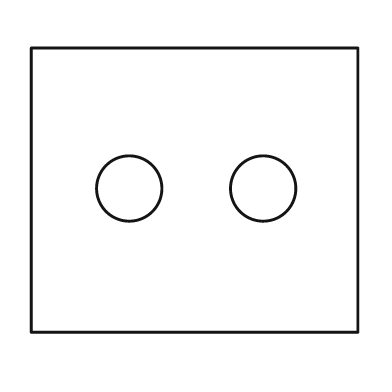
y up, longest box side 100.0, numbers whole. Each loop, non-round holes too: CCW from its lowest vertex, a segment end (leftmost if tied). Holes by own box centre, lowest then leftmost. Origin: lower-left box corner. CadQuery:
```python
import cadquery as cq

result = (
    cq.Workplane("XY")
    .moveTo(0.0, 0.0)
    .lineTo(100.0, 0.0)
    .lineTo(100.0, 87.0)
    .lineTo(0.0, 87.0)
    .close()
    .moveTo(30.0, 44.0)
    .circle(10.0)
    .moveTo(71.0, 44.0)
    .circle(10.0)
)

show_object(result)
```